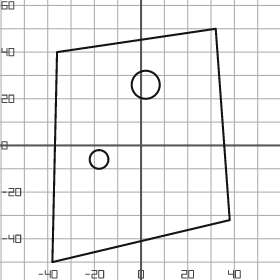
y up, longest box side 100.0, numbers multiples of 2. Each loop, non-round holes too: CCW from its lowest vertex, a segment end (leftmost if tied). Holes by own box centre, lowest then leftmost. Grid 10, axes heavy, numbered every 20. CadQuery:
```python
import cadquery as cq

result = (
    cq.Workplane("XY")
    .moveTo(-38.0, -50.0)
    .lineTo(38.0, -32.0)
    .lineTo(32.0, 50.0)
    .lineTo(-36.0, 40.0)
    .close()
    .moveTo(-18.0, -6.0)
    .circle(4.0)
    .moveTo(2.0, 26.0)
    .circle(6.0)
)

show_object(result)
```